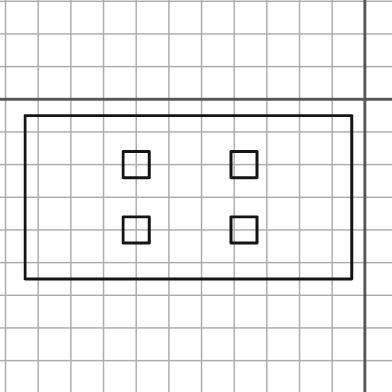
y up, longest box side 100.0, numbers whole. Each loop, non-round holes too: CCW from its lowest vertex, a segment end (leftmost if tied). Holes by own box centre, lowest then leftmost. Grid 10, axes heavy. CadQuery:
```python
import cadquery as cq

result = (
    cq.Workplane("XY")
    .moveTo(-104.0, -55.0)
    .lineTo(-4.0, -55.0)
    .lineTo(-4.0, -5.0)
    .lineTo(-104.0, -5.0)
    .close()
    .moveTo(-74.0, -44.0)
    .lineTo(-66.0, -44.0)
    .lineTo(-66.0, -36.0)
    .lineTo(-74.0, -36.0)
    .close()
    .moveTo(-41.0, -44.0)
    .lineTo(-33.0, -44.0)
    .lineTo(-33.0, -36.0)
    .lineTo(-41.0, -36.0)
    .close()
    .moveTo(-74.0, -24.0)
    .lineTo(-66.0, -24.0)
    .lineTo(-66.0, -16.0)
    .lineTo(-74.0, -16.0)
    .close()
    .moveTo(-41.0, -24.0)
    .lineTo(-33.0, -24.0)
    .lineTo(-33.0, -16.0)
    .lineTo(-41.0, -16.0)
    .close()
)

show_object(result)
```